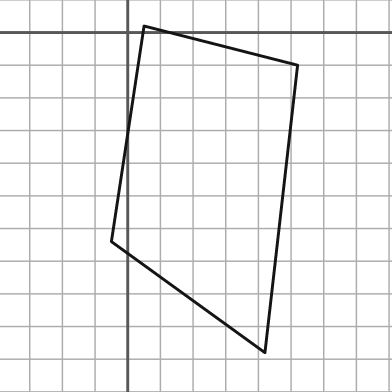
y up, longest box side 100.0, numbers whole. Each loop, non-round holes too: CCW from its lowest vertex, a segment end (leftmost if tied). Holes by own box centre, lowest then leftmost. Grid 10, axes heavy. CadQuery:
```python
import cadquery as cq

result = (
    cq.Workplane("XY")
    .moveTo(42.0, -98.0)
    .lineTo(52.0, -10.0)
    .lineTo(5.0, 2.0)
    .lineTo(-5.0, -64.0)
    .close()
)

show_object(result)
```